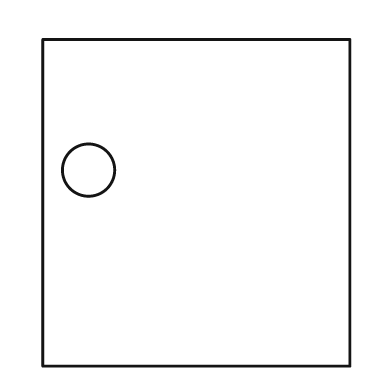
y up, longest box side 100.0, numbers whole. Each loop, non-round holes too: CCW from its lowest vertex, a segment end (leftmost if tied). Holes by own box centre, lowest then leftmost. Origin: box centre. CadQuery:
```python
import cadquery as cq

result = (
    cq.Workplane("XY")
    .moveTo(-47.0, -50.0)
    .lineTo(47.0, -50.0)
    .lineTo(47.0, 50.0)
    .lineTo(-47.0, 50.0)
    .close()
    .moveTo(-33.0, 10.0)
    .circle(8.0)
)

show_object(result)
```